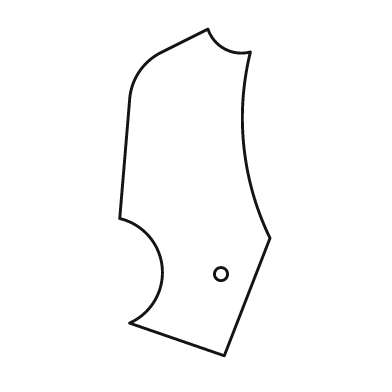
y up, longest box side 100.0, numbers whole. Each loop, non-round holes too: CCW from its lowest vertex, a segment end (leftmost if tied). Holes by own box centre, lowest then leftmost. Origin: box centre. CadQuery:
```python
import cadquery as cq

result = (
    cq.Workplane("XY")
    .moveTo(9.0, -50.0)
    .lineTo(23.0, -14.0)
    .threePointArc((15.0, 14.0), (17.0, 43.0))
    .threePointArc((9.0, 44.0), (4.0, 50.0))
    .lineTo(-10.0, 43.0)
    .threePointArc((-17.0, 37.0), (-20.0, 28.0))
    .lineTo(-23.0, -8.0)
    .threePointArc((-10.0, -23.0), (-20.0, -40.0))
    .close()
    .moveTo(8.0, -25.0)
    .circle(2.0)
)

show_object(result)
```